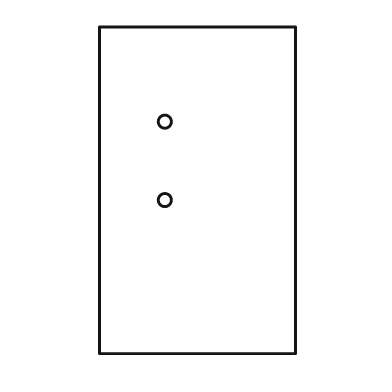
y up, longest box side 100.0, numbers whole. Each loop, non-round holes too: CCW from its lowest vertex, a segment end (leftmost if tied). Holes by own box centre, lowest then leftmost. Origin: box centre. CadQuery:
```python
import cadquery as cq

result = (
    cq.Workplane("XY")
    .moveTo(-30.0, -50.0)
    .lineTo(30.0, -50.0)
    .lineTo(30.0, 50.0)
    .lineTo(-30.0, 50.0)
    .close()
    .moveTo(-10.0, -3.0)
    .circle(2.0)
    .moveTo(-10.0, 21.0)
    .circle(2.0)
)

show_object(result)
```